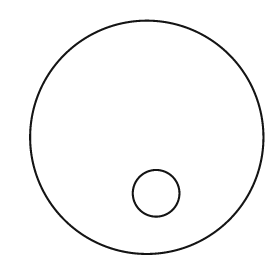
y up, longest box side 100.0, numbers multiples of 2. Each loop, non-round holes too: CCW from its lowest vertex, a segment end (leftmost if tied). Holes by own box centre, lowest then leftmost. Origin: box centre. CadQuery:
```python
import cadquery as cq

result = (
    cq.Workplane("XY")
    .moveTo(0.0, 0.0)
    .circle(50.0)
    .moveTo(4.0, -24.0)
    .circle(10.0)
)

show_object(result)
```